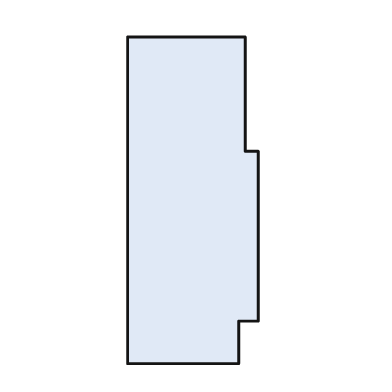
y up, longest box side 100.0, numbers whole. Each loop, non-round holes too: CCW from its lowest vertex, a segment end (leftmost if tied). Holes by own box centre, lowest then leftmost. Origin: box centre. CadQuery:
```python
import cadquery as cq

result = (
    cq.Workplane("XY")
    .moveTo(-20.0, -50.0)
    .lineTo(14.0, -50.0)
    .lineTo(14.0, -37.0)
    .lineTo(20.0, -37.0)
    .lineTo(20.0, 15.0)
    .lineTo(16.0, 15.0)
    .lineTo(16.0, 50.0)
    .lineTo(-20.0, 50.0)
    .close()
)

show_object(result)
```